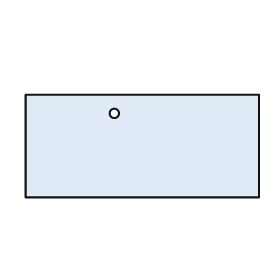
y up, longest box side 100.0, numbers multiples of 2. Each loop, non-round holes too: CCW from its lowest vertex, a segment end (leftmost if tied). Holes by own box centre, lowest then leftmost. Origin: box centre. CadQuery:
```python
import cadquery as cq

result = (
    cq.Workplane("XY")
    .moveTo(-50.0, -22.0)
    .lineTo(50.0, -22.0)
    .lineTo(50.0, 22.0)
    .lineTo(-50.0, 22.0)
    .close()
    .moveTo(-12.0, 14.0)
    .circle(2.0)
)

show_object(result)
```